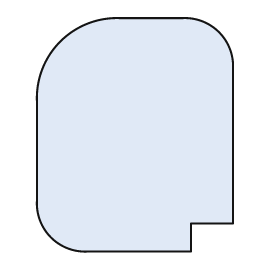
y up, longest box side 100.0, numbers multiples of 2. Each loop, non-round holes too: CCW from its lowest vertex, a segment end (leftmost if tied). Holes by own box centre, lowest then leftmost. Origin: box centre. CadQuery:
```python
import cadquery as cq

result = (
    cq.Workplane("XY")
    .moveTo(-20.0, -50.0)
    .lineTo(24.0, -50.0)
    .lineTo(24.0, -38.0)
    .lineTo(42.0, -38.0)
    .lineTo(42.0, 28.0)
    .threePointArc((36.0, 44.0), (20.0, 50.0))
    .lineTo(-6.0, 50.0)
    .threePointArc((-32.0, 40.0), (-42.0, 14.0))
    .lineTo(-42.0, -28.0)
    .threePointArc((-36.0, -44.0), (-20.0, -50.0))
    .close()
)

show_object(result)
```